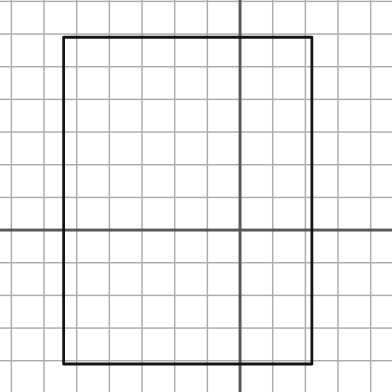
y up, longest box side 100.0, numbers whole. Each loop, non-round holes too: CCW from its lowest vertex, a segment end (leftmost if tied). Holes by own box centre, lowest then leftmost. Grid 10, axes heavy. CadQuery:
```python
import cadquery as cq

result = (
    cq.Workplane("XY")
    .moveTo(-54.0, -41.0)
    .lineTo(22.0, -41.0)
    .lineTo(22.0, 59.0)
    .lineTo(-54.0, 59.0)
    .close()
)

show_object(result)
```